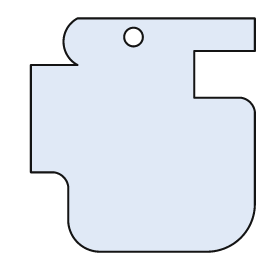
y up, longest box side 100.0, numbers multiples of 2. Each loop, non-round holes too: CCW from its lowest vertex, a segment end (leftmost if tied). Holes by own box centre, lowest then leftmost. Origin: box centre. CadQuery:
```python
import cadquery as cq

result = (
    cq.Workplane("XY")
    .moveTo(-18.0, -50.0)
    .lineTo(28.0, -50.0)
    .threePointArc((42.0, -44.0), (48.0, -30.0))
    .lineTo(48.0, 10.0)
    .threePointArc((46.0, 14.0), (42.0, 16.0))
    .lineTo(22.0, 16.0)
    .lineTo(22.0, 36.0)
    .lineTo(48.0, 36.0)
    .lineTo(48.0, 50.0)
    .lineTo(-28.0, 50.0)
    .threePointArc((-34.0, 40.0), (-28.0, 30.0))
    .lineTo(-48.0, 30.0)
    .lineTo(-48.0, -16.0)
    .lineTo(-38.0, -16.0)
    .threePointArc((-34.0, -18.0), (-32.0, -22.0))
    .lineTo(-32.0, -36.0)
    .threePointArc((-28.0, -46.0), (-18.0, -50.0))
    .close()
    .moveTo(-4.0, 42.0)
    .circle(4.0)
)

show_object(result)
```